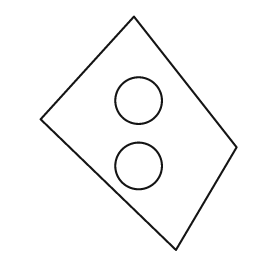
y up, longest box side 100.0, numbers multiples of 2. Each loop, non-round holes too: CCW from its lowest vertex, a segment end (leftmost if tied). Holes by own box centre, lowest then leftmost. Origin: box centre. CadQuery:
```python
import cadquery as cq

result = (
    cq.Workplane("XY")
    .moveTo(16.0, -50.0)
    .lineTo(42.0, -6.0)
    .lineTo(-2.0, 50.0)
    .lineTo(-42.0, 6.0)
    .close()
    .moveTo(0.0, -14.0)
    .circle(10.0)
    .moveTo(0.0, 14.0)
    .circle(10.0)
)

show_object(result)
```